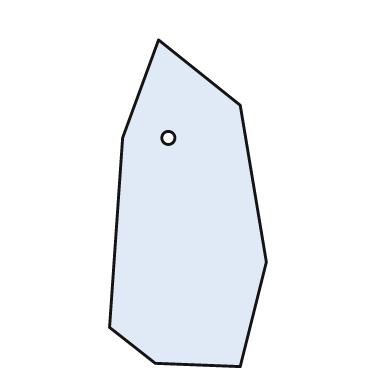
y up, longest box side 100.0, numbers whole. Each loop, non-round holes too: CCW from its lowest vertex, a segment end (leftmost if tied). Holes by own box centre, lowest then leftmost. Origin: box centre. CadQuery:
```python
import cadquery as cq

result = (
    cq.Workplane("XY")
    .moveTo(16.0, -50.0)
    .lineTo(24.0, -18.0)
    .lineTo(16.0, 30.0)
    .lineTo(-9.0, 50.0)
    .lineTo(-20.0, 20.0)
    .lineTo(-24.0, -38.0)
    .lineTo(-10.0, -49.0)
    .close()
    .moveTo(-6.0, 20.0)
    .circle(2.0)
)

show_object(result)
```